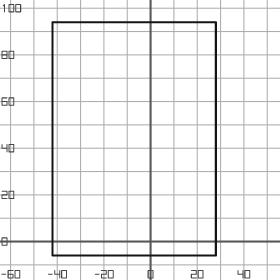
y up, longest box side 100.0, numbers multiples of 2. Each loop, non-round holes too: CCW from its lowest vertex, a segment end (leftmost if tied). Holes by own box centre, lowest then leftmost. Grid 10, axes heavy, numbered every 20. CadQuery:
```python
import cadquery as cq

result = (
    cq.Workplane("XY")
    .moveTo(-42.0, -6.0)
    .lineTo(28.0, -6.0)
    .lineTo(28.0, 94.0)
    .lineTo(-42.0, 94.0)
    .close()
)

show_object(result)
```